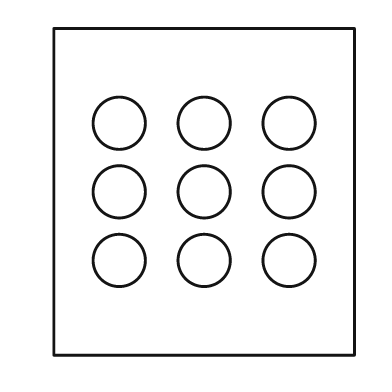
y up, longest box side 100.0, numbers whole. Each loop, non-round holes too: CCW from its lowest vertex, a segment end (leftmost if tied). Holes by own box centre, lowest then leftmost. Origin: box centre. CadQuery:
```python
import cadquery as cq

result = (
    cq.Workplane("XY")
    .moveTo(-46.0, -50.0)
    .lineTo(46.0, -50.0)
    .lineTo(46.0, 50.0)
    .lineTo(-46.0, 50.0)
    .close()
    .moveTo(-26.0, -21.0)
    .circle(8.0)
    .moveTo(0.0, -21.0)
    .circle(8.0)
    .moveTo(26.0, -21.0)
    .circle(8.0)
    .moveTo(-26.0, 0.0)
    .circle(8.0)
    .moveTo(0.0, 0.0)
    .circle(8.0)
    .moveTo(26.0, 0.0)
    .circle(8.0)
    .moveTo(-26.0, 21.0)
    .circle(8.0)
    .moveTo(0.0, 21.0)
    .circle(8.0)
    .moveTo(26.0, 21.0)
    .circle(8.0)
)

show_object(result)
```